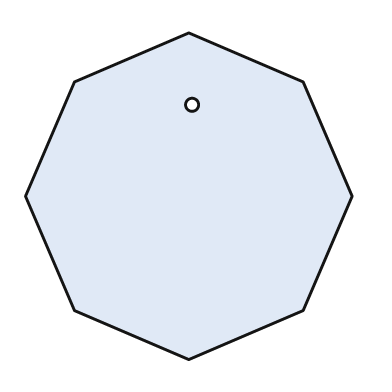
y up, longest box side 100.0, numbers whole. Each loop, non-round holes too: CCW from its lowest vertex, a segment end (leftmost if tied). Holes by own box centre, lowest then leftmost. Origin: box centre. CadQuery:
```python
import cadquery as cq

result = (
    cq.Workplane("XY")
    .moveTo(0.0, -50.0)
    .lineTo(35.0, -35.0)
    .lineTo(50.0, 0.0)
    .lineTo(35.0, 35.0)
    .lineTo(0.0, 50.0)
    .lineTo(-35.0, 35.0)
    .lineTo(-50.0, 0.0)
    .lineTo(-35.0, -35.0)
    .close()
    .moveTo(1.0, 28.0)
    .circle(2.0)
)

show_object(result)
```